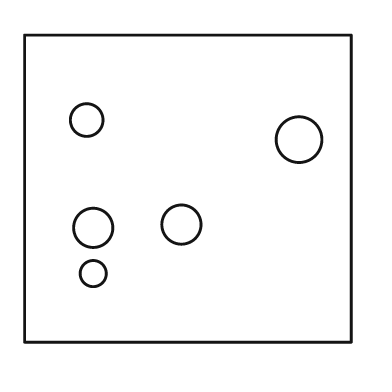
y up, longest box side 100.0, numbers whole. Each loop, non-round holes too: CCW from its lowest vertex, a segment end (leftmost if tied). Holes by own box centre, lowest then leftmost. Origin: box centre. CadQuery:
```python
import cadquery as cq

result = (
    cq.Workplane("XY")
    .moveTo(-50.0, -47.0)
    .lineTo(50.0, -47.0)
    .lineTo(50.0, 47.0)
    .lineTo(-50.0, 47.0)
    .close()
    .moveTo(-29.0, -26.0)
    .circle(4.0)
    .moveTo(-29.0, -12.0)
    .circle(6.0)
    .moveTo(-2.0, -11.0)
    .circle(6.0)
    .moveTo(34.0, 15.0)
    .circle(7.0)
    .moveTo(-31.0, 21.0)
    .circle(5.0)
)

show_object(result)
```